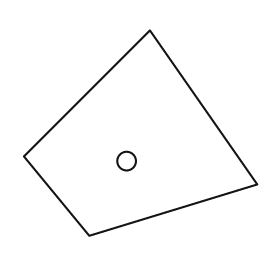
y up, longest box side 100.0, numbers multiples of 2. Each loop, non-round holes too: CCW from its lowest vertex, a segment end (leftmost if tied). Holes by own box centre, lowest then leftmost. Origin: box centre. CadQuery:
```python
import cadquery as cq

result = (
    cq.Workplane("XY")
    .moveTo(-22.0, -44.0)
    .lineTo(50.0, -22.0)
    .lineTo(4.0, 44.0)
    .lineTo(-50.0, -10.0)
    .close()
    .moveTo(-6.0, -12.0)
    .circle(4.0)
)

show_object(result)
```